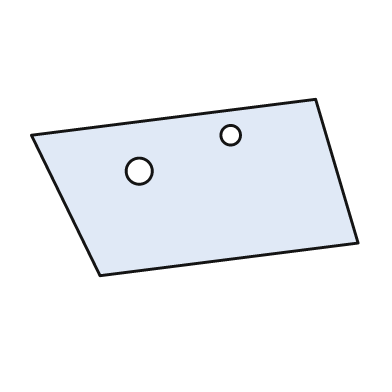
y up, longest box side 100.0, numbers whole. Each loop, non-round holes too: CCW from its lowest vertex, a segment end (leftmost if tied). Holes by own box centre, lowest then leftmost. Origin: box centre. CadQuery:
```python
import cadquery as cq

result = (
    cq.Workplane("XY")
    .moveTo(-29.0, -27.0)
    .lineTo(50.0, -17.0)
    .lineTo(37.0, 27.0)
    .lineTo(-50.0, 16.0)
    .close()
    .moveTo(-17.0, 5.0)
    .circle(4.0)
    .moveTo(11.0, 16.0)
    .circle(3.0)
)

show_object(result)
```